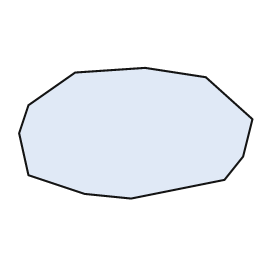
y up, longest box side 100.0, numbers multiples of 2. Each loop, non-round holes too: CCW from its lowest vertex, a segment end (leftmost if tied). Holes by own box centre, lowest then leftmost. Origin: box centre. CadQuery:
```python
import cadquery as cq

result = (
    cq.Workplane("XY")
    .moveTo(-2.0, -28.0)
    .lineTo(38.0, -20.0)
    .lineTo(46.0, -10.0)
    .lineTo(50.0, 6.0)
    .lineTo(30.0, 24.0)
    .lineTo(4.0, 28.0)
    .lineTo(-26.0, 26.0)
    .lineTo(-46.0, 12.0)
    .lineTo(-50.0, 0.0)
    .lineTo(-46.0, -18.0)
    .lineTo(-22.0, -26.0)
    .close()
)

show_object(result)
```